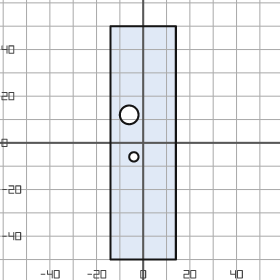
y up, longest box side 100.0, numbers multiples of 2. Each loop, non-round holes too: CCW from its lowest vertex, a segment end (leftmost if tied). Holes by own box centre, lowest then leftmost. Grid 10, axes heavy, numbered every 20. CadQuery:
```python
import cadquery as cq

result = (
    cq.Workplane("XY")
    .moveTo(-14.0, -50.0)
    .lineTo(14.0, -50.0)
    .lineTo(14.0, 50.0)
    .lineTo(-14.0, 50.0)
    .close()
    .moveTo(-4.0, -6.0)
    .circle(2.0)
    .moveTo(-6.0, 12.0)
    .circle(4.0)
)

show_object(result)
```